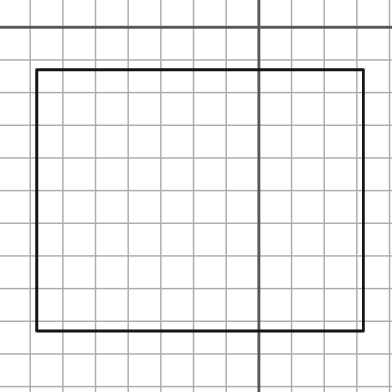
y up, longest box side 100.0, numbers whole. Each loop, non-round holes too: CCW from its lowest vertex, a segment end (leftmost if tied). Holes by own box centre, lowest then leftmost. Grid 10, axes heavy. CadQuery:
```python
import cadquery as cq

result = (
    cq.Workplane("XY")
    .moveTo(-68.0, -93.0)
    .lineTo(32.0, -93.0)
    .lineTo(32.0, -13.0)
    .lineTo(-68.0, -13.0)
    .close()
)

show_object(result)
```